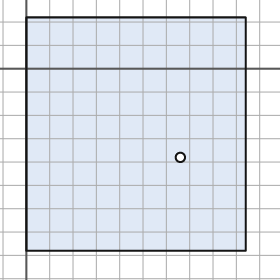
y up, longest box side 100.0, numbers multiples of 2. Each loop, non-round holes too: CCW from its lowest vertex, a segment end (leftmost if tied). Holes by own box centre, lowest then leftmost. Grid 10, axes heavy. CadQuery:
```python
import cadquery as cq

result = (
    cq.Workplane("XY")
    .moveTo(0.0, -78.0)
    .lineTo(94.0, -78.0)
    .lineTo(94.0, 22.0)
    .lineTo(0.0, 22.0)
    .close()
    .moveTo(66.0, -38.0)
    .circle(2.0)
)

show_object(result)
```